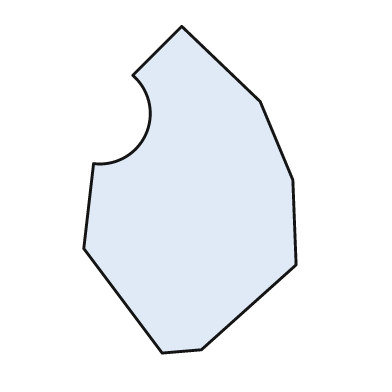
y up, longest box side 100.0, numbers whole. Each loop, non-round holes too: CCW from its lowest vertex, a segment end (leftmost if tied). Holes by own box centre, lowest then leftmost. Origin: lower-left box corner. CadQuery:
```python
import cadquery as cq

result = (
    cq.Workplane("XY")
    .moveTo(24.0, 0.0)
    .lineTo(36.0, 1.0)
    .lineTo(65.0, 27.0)
    .lineTo(64.0, 53.0)
    .lineTo(54.0, 77.0)
    .lineTo(30.0, 100.0)
    .lineTo(15.0, 85.0)
    .threePointArc((19.0, 67.0), (3.0, 58.0))
    .lineTo(0.0, 32.0)
    .close()
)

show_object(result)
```